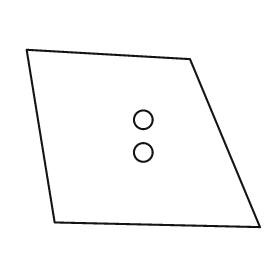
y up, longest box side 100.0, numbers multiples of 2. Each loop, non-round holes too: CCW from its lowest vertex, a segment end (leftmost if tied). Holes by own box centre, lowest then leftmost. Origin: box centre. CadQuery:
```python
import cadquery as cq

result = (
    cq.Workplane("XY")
    .moveTo(50.0, -38.0)
    .lineTo(20.0, 34.0)
    .lineTo(-50.0, 38.0)
    .lineTo(-38.0, -36.0)
    .close()
    .moveTo(0.0, -6.0)
    .circle(4.0)
    .moveTo(0.0, 8.0)
    .circle(4.0)
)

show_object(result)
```